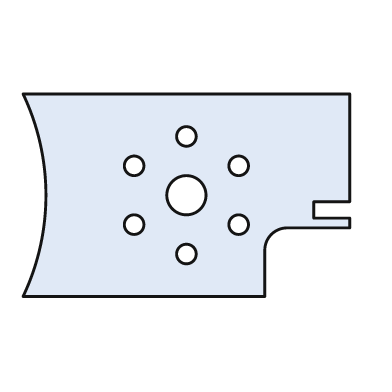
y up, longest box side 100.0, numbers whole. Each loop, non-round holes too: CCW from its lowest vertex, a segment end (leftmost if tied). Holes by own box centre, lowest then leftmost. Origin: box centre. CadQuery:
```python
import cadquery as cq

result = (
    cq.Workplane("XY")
    .moveTo(-50.0, -31.0)
    .lineTo(24.0, -31.0)
    .lineTo(24.0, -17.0)
    .threePointArc((26.0, -12.0), (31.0, -10.0))
    .lineTo(50.0, -10.0)
    .lineTo(50.0, -7.0)
    .lineTo(39.0, -7.0)
    .lineTo(39.0, -2.0)
    .lineTo(50.0, -2.0)
    .lineTo(50.0, 31.0)
    .lineTo(-50.0, 31.0)
    .threePointArc((-43.0, 0.0), (-50.0, -31.0))
    .close()
    .moveTo(0.0, -18.0)
    .circle(3.0)
    .moveTo(-16.0, -9.0)
    .circle(3.0)
    .moveTo(16.0, -9.0)
    .circle(3.0)
    .moveTo(0.0, 0.0)
    .circle(6.0)
    .moveTo(-16.0, 9.0)
    .circle(3.0)
    .moveTo(16.0, 9.0)
    .circle(3.0)
    .moveTo(0.0, 18.0)
    .circle(3.0)
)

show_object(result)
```